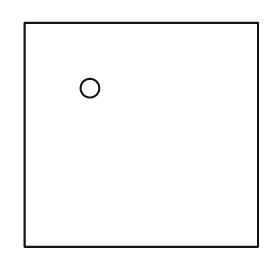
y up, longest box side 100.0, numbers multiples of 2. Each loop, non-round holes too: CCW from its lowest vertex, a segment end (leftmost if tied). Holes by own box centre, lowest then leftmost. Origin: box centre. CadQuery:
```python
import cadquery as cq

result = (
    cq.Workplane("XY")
    .moveTo(-50.0, -48.0)
    .lineTo(50.0, -48.0)
    .lineTo(50.0, 48.0)
    .lineTo(-50.0, 48.0)
    .close()
    .moveTo(-22.0, 20.0)
    .circle(4.0)
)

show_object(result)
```